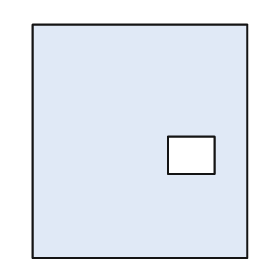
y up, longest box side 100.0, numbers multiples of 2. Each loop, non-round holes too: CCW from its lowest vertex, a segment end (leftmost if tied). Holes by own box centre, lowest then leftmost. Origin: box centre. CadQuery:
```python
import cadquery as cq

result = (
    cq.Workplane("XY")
    .moveTo(-46.0, -50.0)
    .lineTo(46.0, -50.0)
    .lineTo(46.0, 50.0)
    .lineTo(-46.0, 50.0)
    .close()
    .moveTo(12.0, -14.0)
    .lineTo(32.0, -14.0)
    .lineTo(32.0, 2.0)
    .lineTo(12.0, 2.0)
    .close()
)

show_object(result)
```